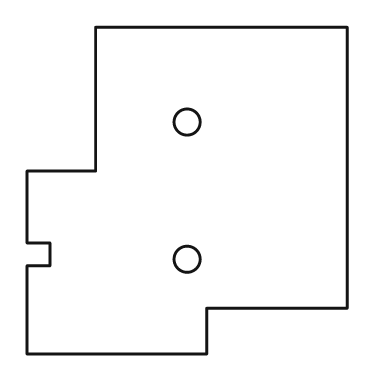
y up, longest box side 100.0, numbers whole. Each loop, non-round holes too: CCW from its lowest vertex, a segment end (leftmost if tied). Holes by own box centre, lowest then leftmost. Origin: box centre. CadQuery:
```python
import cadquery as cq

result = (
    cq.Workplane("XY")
    .moveTo(-49.0, -50.0)
    .lineTo(6.0, -50.0)
    .lineTo(6.0, -36.0)
    .lineTo(49.0, -36.0)
    .lineTo(49.0, 50.0)
    .lineTo(-28.0, 50.0)
    .lineTo(-28.0, 6.0)
    .lineTo(-49.0, 6.0)
    .lineTo(-49.0, -16.0)
    .lineTo(-42.0, -16.0)
    .lineTo(-42.0, -23.0)
    .lineTo(-49.0, -23.0)
    .close()
    .moveTo(0.0, -21.0)
    .circle(4.0)
    .moveTo(0.0, 21.0)
    .circle(4.0)
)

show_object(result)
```